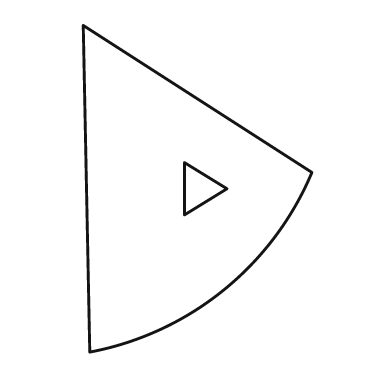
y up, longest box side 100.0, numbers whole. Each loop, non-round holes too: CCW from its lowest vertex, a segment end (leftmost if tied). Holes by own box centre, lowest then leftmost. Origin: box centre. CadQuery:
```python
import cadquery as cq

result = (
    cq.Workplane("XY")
    .moveTo(-33.0, -50.0)
    .threePointArc((8.0, -31.0), (35.0, 5.0))
    .lineTo(-35.0, 50.0)
    .close()
    .moveTo(-4.0, -8.0)
    .lineTo(9.0, 0.0)
    .lineTo(-4.0, 8.0)
    .close()
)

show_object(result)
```